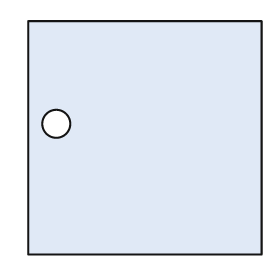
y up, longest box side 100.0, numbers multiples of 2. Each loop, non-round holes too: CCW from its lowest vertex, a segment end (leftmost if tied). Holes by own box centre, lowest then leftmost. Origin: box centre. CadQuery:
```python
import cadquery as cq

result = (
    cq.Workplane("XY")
    .moveTo(-50.0, -50.0)
    .lineTo(50.0, -50.0)
    .lineTo(50.0, 50.0)
    .lineTo(-50.0, 50.0)
    .close()
    .moveTo(-38.0, 6.0)
    .circle(6.0)
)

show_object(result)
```